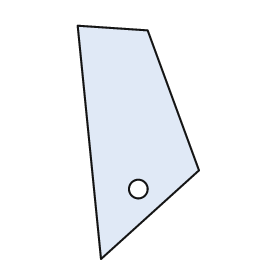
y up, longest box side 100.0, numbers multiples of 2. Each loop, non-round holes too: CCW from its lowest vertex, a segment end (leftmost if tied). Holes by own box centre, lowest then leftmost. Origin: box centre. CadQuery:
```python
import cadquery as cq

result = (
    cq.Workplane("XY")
    .moveTo(-16.0, -50.0)
    .lineTo(26.0, -12.0)
    .lineTo(4.0, 48.0)
    .lineTo(-26.0, 50.0)
    .close()
    .moveTo(0.0, -20.0)
    .circle(4.0)
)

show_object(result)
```